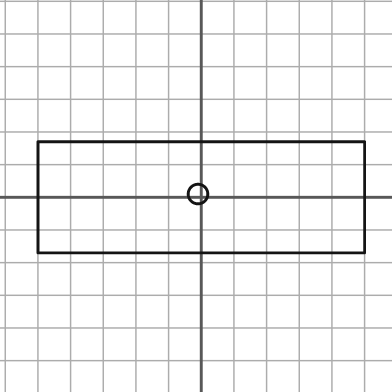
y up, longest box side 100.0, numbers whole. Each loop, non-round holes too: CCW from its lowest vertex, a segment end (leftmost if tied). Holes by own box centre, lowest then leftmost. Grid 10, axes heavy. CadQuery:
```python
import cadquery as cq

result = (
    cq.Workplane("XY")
    .moveTo(-50.0, -17.0)
    .lineTo(50.0, -17.0)
    .lineTo(50.0, 17.0)
    .lineTo(-50.0, 17.0)
    .close()
    .moveTo(-1.0, 1.0)
    .circle(3.0)
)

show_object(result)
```